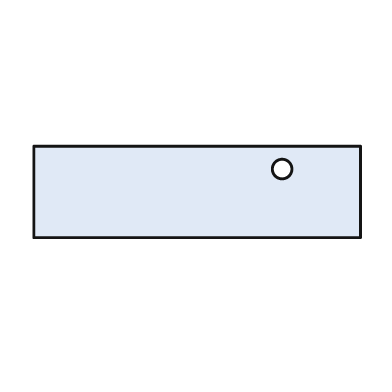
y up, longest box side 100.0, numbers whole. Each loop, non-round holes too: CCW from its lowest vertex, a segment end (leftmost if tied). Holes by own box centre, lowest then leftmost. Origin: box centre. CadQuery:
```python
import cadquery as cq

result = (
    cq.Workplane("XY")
    .moveTo(-50.0, -14.0)
    .lineTo(50.0, -14.0)
    .lineTo(50.0, 14.0)
    .lineTo(-50.0, 14.0)
    .close()
    .moveTo(26.0, 7.0)
    .circle(3.0)
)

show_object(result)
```